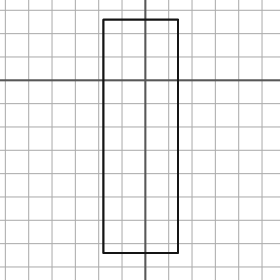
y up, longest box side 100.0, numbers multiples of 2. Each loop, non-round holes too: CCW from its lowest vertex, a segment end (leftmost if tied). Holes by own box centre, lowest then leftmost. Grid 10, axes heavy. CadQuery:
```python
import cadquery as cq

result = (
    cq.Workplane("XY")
    .moveTo(-18.0, -74.0)
    .lineTo(14.0, -74.0)
    .lineTo(14.0, 26.0)
    .lineTo(-18.0, 26.0)
    .close()
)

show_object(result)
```